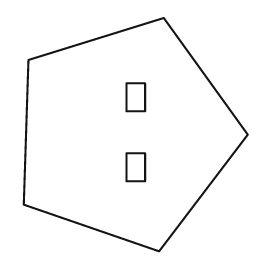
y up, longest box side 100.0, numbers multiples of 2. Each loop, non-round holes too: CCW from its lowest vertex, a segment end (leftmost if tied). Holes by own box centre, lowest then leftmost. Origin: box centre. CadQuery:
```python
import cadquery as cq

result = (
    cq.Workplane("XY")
    .moveTo(10.0, -50.0)
    .lineTo(48.0, 0.0)
    .lineTo(12.0, 50.0)
    .lineTo(-46.0, 32.0)
    .lineTo(-48.0, -30.0)
    .close()
    .moveTo(-4.0, -20.0)
    .lineTo(4.0, -20.0)
    .lineTo(4.0, -8.0)
    .lineTo(-4.0, -8.0)
    .close()
    .moveTo(-4.0, 10.0)
    .lineTo(4.0, 10.0)
    .lineTo(4.0, 22.0)
    .lineTo(-4.0, 22.0)
    .close()
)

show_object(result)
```